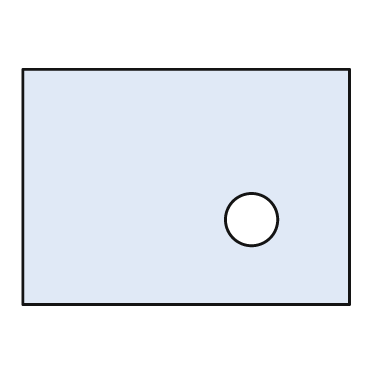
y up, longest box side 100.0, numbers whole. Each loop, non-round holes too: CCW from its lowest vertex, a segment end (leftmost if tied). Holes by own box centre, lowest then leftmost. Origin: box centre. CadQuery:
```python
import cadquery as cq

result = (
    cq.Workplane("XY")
    .moveTo(-50.0, -36.0)
    .lineTo(50.0, -36.0)
    .lineTo(50.0, 36.0)
    .lineTo(-50.0, 36.0)
    .close()
    .moveTo(20.0, -10.0)
    .circle(8.0)
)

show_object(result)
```